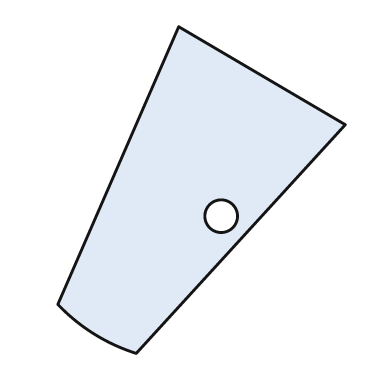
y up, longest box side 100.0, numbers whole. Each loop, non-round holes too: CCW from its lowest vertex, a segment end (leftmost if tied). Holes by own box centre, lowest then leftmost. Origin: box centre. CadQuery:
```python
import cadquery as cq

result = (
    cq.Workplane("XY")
    .moveTo(-20.0, -50.0)
    .lineTo(44.0, 20.0)
    .lineTo(-7.0, 50.0)
    .lineTo(-44.0, -35.0)
    .threePointArc((-33.0, -44.0), (-20.0, -50.0))
    .close()
    .moveTo(6.0, -8.0)
    .circle(5.0)
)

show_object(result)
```